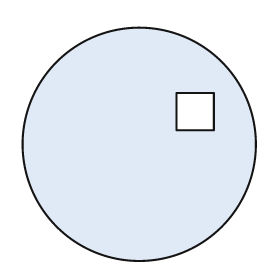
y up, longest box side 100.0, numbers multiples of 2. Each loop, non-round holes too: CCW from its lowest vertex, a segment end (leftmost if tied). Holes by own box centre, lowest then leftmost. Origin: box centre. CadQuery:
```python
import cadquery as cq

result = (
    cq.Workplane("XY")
    .moveTo(0.0, 0.0)
    .circle(50.0)
    .moveTo(16.0, 6.0)
    .lineTo(32.0, 6.0)
    .lineTo(32.0, 22.0)
    .lineTo(16.0, 22.0)
    .close()
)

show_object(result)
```